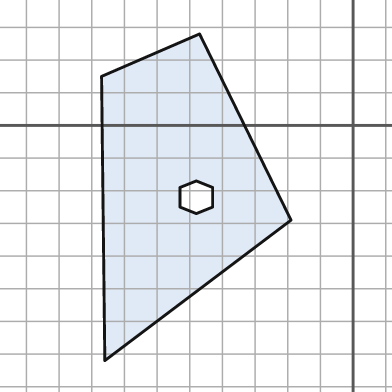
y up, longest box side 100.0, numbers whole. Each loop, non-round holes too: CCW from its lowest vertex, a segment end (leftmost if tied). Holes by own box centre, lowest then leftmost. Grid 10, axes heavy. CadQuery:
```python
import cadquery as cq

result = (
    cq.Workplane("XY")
    .moveTo(-76.0, -72.0)
    .lineTo(-19.0, -29.0)
    .lineTo(-47.0, 28.0)
    .lineTo(-77.0, 15.0)
    .close()
    .moveTo(-48.0, -27.0)
    .lineTo(-43.0, -25.0)
    .lineTo(-43.0, -19.0)
    .lineTo(-48.0, -17.0)
    .lineTo(-53.0, -19.0)
    .lineTo(-53.0, -25.0)
    .close()
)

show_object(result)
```